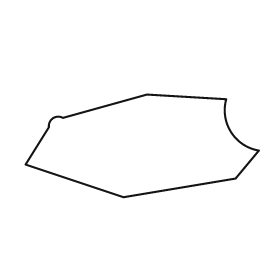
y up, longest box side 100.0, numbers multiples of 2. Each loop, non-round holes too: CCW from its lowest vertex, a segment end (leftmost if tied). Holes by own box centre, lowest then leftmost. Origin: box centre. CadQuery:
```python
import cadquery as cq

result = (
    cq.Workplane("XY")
    .moveTo(-8.0, -22.0)
    .lineTo(40.0, -14.0)
    .lineTo(50.0, -2.0)
    .threePointArc((38.0, 6.0), (36.0, 20.0))
    .lineTo(2.0, 22.0)
    .lineTo(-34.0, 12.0)
    .threePointArc((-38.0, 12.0), (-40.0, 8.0))
    .lineTo(-50.0, -8.0)
    .close()
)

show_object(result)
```